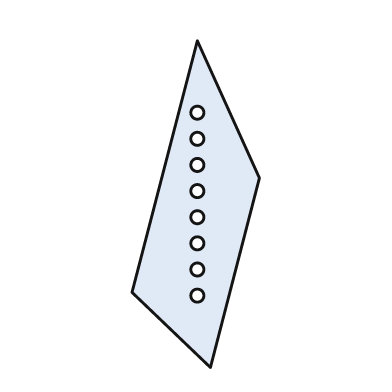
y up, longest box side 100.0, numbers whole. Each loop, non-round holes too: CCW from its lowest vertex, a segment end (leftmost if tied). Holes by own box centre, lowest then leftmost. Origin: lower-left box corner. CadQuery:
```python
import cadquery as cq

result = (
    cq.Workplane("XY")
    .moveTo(24.0, 0.0)
    .lineTo(39.0, 58.0)
    .lineTo(20.0, 100.0)
    .lineTo(0.0, 23.0)
    .close()
    .moveTo(20.0, 22.0)
    .circle(2.0)
    .moveTo(20.0, 30.0)
    .circle(2.0)
    .moveTo(20.0, 38.0)
    .circle(2.0)
    .moveTo(20.0, 46.0)
    .circle(2.0)
    .moveTo(20.0, 54.0)
    .circle(2.0)
    .moveTo(20.0, 62.0)
    .circle(2.0)
    .moveTo(20.0, 70.0)
    .circle(2.0)
    .moveTo(20.0, 78.0)
    .circle(2.0)
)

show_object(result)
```